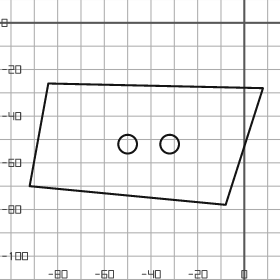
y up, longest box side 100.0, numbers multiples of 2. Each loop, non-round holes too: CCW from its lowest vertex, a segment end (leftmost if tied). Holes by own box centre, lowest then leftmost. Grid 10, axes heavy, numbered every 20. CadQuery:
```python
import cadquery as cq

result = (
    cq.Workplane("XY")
    .moveTo(-8.0, -78.0)
    .lineTo(8.0, -28.0)
    .lineTo(-84.0, -26.0)
    .lineTo(-92.0, -70.0)
    .close()
    .moveTo(-50.0, -52.0)
    .circle(4.0)
    .moveTo(-32.0, -52.0)
    .circle(4.0)
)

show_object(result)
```